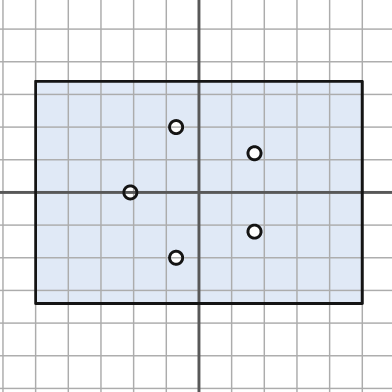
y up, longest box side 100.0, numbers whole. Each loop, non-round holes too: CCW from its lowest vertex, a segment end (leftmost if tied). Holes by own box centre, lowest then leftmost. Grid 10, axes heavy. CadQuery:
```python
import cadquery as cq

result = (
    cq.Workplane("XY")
    .moveTo(-50.0, -34.0)
    .lineTo(50.0, -34.0)
    .lineTo(50.0, 34.0)
    .lineTo(-50.0, 34.0)
    .close()
    .moveTo(-7.0, -20.0)
    .circle(2.0)
    .moveTo(17.0, -12.0)
    .circle(2.0)
    .moveTo(-21.0, 0.0)
    .circle(2.0)
    .moveTo(17.0, 12.0)
    .circle(2.0)
    .moveTo(-7.0, 20.0)
    .circle(2.0)
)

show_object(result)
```